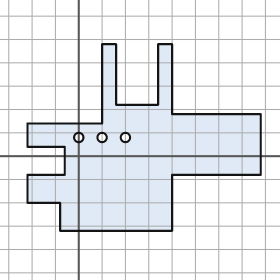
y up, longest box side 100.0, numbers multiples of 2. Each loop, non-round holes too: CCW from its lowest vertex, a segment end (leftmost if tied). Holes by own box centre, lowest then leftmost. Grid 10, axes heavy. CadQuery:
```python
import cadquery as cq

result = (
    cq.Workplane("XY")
    .moveTo(-8.0, -32.0)
    .lineTo(40.0, -32.0)
    .lineTo(40.0, -8.0)
    .lineTo(78.0, -8.0)
    .lineTo(78.0, 18.0)
    .lineTo(40.0, 18.0)
    .lineTo(40.0, 48.0)
    .lineTo(34.0, 48.0)
    .lineTo(34.0, 22.0)
    .lineTo(16.0, 22.0)
    .lineTo(16.0, 48.0)
    .lineTo(10.0, 48.0)
    .lineTo(10.0, 14.0)
    .lineTo(-22.0, 14.0)
    .lineTo(-22.0, 4.0)
    .lineTo(-6.0, 4.0)
    .lineTo(-6.0, -8.0)
    .lineTo(-22.0, -8.0)
    .lineTo(-22.0, -20.0)
    .lineTo(-8.0, -20.0)
    .close()
    .moveTo(0.0, 8.0)
    .circle(2.0)
    .moveTo(10.0, 8.0)
    .circle(2.0)
    .moveTo(20.0, 8.0)
    .circle(2.0)
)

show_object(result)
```